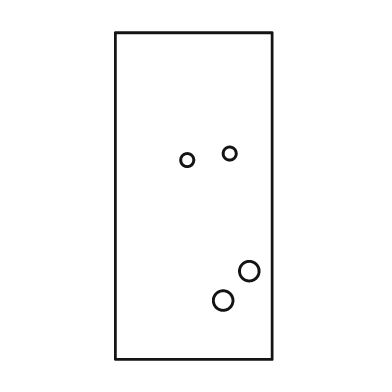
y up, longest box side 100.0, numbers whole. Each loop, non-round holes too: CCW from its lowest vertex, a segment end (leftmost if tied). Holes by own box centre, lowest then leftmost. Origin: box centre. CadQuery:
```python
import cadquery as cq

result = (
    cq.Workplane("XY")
    .moveTo(-24.0, -50.0)
    .lineTo(24.0, -50.0)
    .lineTo(24.0, 50.0)
    .lineTo(-24.0, 50.0)
    .close()
    .moveTo(9.0, -32.0)
    .circle(3.0)
    .moveTo(17.0, -23.0)
    .circle(3.0)
    .moveTo(-2.0, 11.0)
    .circle(2.0)
    .moveTo(11.0, 13.0)
    .circle(2.0)
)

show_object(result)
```